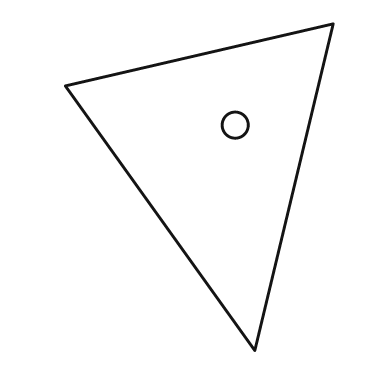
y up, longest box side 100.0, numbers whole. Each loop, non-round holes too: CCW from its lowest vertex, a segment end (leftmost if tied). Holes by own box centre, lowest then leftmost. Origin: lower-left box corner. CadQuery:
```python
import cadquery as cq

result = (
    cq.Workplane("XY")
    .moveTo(58.0, 0.0)
    .lineTo(82.0, 100.0)
    .lineTo(0.0, 81.0)
    .close()
    .moveTo(52.0, 69.0)
    .circle(4.0)
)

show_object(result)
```